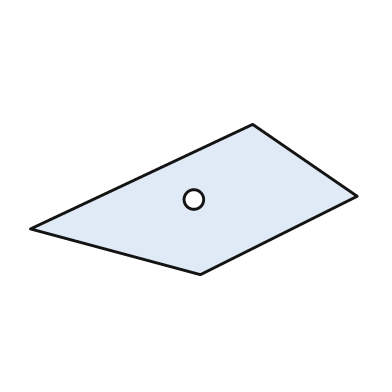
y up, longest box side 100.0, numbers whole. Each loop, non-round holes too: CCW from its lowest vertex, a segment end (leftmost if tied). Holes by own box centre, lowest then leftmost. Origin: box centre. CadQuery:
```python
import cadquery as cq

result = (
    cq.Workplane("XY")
    .moveTo(2.0, -23.0)
    .lineTo(50.0, 1.0)
    .lineTo(18.0, 23.0)
    .lineTo(-50.0, -9.0)
    .close()
    .moveTo(0.0, 0.0)
    .circle(3.0)
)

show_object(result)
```